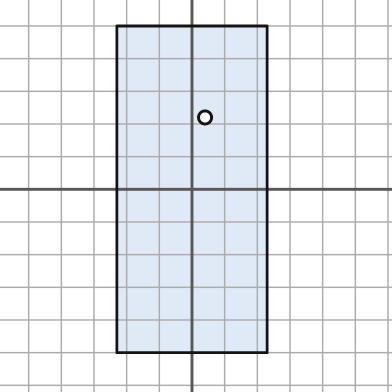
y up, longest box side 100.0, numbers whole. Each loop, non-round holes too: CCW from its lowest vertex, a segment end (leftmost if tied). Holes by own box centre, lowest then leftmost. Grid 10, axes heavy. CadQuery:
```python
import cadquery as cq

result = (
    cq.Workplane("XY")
    .moveTo(-23.0, -50.0)
    .lineTo(23.0, -50.0)
    .lineTo(23.0, 50.0)
    .lineTo(-23.0, 50.0)
    .close()
    .moveTo(4.0, 22.0)
    .circle(2.0)
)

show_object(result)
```